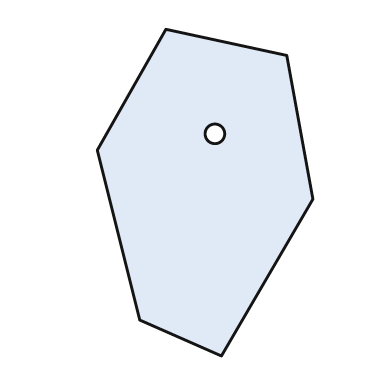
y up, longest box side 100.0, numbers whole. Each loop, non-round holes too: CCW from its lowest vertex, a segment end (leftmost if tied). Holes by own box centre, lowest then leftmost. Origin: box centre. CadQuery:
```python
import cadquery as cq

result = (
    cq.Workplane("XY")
    .moveTo(5.0, -50.0)
    .lineTo(33.0, -2.0)
    .lineTo(25.0, 42.0)
    .lineTo(-12.0, 50.0)
    .lineTo(-33.0, 13.0)
    .lineTo(-20.0, -39.0)
    .close()
    .moveTo(3.0, 18.0)
    .circle(3.0)
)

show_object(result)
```